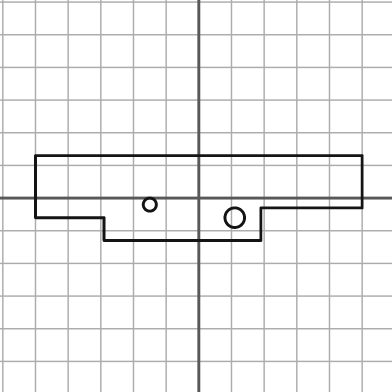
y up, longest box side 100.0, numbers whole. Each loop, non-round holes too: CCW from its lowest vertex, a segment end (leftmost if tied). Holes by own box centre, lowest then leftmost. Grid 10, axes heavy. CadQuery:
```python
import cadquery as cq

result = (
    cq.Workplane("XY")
    .moveTo(-29.0, -13.0)
    .lineTo(19.0, -13.0)
    .lineTo(19.0, -3.0)
    .lineTo(50.0, -3.0)
    .lineTo(50.0, 13.0)
    .lineTo(-50.0, 13.0)
    .lineTo(-50.0, -6.0)
    .lineTo(-29.0, -6.0)
    .close()
    .moveTo(11.0, -6.0)
    .circle(3.0)
    .moveTo(-15.0, -2.0)
    .circle(2.0)
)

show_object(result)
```